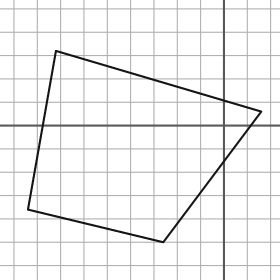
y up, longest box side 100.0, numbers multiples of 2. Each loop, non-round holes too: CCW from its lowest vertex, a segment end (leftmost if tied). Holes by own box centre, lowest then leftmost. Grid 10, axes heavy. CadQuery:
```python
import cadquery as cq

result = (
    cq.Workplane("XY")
    .moveTo(-26.0, -50.0)
    .lineTo(16.0, 6.0)
    .lineTo(-72.0, 32.0)
    .lineTo(-84.0, -36.0)
    .close()
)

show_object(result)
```